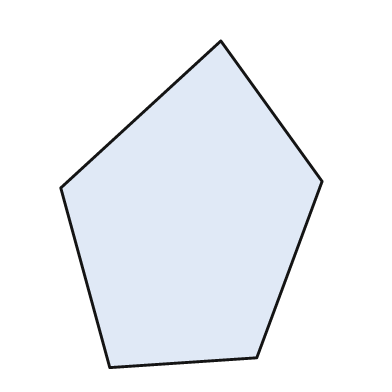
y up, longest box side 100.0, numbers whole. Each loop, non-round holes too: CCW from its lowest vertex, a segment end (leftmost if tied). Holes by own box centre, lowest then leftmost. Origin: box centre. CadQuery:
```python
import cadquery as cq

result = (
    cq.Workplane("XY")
    .moveTo(-25.0, -50.0)
    .lineTo(20.0, -47.0)
    .lineTo(40.0, 7.0)
    .lineTo(9.0, 50.0)
    .lineTo(-40.0, 5.0)
    .close()
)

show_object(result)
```